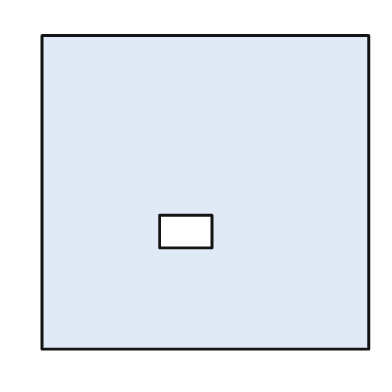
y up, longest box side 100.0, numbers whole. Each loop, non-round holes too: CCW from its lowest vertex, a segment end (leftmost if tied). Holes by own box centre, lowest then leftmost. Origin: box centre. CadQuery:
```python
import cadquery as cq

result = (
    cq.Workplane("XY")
    .moveTo(-50.0, -48.0)
    .lineTo(50.0, -48.0)
    .lineTo(50.0, 48.0)
    .lineTo(-50.0, 48.0)
    .close()
    .moveTo(-14.0, -17.0)
    .lineTo(2.0, -17.0)
    .lineTo(2.0, -7.0)
    .lineTo(-14.0, -7.0)
    .close()
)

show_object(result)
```